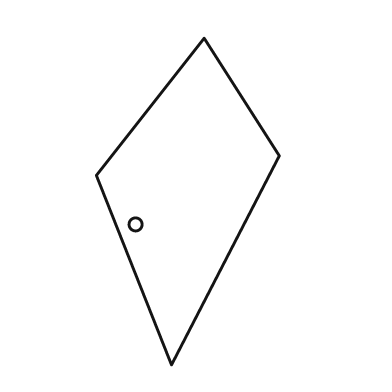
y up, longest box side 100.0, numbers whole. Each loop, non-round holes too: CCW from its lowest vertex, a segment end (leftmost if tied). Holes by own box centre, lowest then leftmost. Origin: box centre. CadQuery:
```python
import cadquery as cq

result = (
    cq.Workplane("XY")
    .moveTo(-5.0, -50.0)
    .lineTo(28.0, 14.0)
    .lineTo(5.0, 50.0)
    .lineTo(-28.0, 8.0)
    .close()
    .moveTo(-16.0, -7.0)
    .circle(2.0)
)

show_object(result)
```